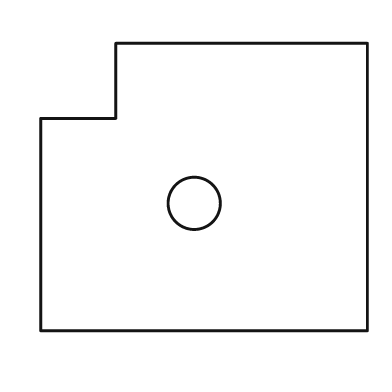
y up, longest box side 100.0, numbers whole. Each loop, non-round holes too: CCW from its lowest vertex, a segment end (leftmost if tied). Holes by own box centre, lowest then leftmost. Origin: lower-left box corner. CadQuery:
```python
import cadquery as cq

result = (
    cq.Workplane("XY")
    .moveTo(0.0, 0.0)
    .lineTo(100.0, 0.0)
    .lineTo(100.0, 88.0)
    .lineTo(23.0, 88.0)
    .lineTo(23.0, 65.0)
    .lineTo(0.0, 65.0)
    .close()
    .moveTo(47.0, 39.0)
    .circle(8.0)
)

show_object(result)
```